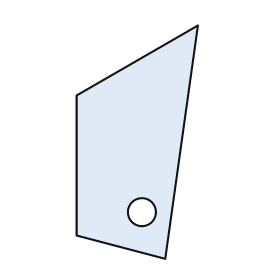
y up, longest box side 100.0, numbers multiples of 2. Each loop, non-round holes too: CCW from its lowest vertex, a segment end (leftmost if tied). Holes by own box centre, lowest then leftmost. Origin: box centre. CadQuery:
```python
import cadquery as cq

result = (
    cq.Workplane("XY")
    .moveTo(12.0, -50.0)
    .lineTo(26.0, 50.0)
    .lineTo(-26.0, 20.0)
    .lineTo(-26.0, -40.0)
    .close()
    .moveTo(2.0, -30.0)
    .circle(6.0)
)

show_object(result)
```